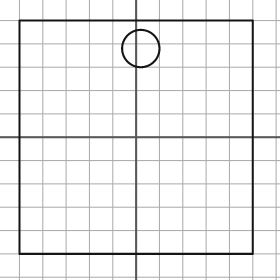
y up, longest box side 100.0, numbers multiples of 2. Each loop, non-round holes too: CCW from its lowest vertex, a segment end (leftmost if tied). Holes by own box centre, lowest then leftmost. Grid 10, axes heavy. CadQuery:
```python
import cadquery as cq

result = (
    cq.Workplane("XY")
    .moveTo(-50.0, -50.0)
    .lineTo(50.0, -50.0)
    .lineTo(50.0, 50.0)
    .lineTo(-50.0, 50.0)
    .close()
    .moveTo(2.0, 38.0)
    .circle(8.0)
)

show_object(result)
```